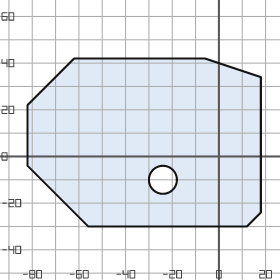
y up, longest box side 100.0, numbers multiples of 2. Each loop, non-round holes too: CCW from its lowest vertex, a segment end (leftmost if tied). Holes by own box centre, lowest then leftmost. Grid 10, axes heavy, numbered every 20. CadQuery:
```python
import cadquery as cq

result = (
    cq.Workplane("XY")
    .moveTo(-56.0, -30.0)
    .lineTo(12.0, -30.0)
    .lineTo(18.0, -24.0)
    .lineTo(18.0, 34.0)
    .lineTo(-6.0, 42.0)
    .lineTo(-62.0, 42.0)
    .lineTo(-82.0, 22.0)
    .lineTo(-82.0, -4.0)
    .close()
    .moveTo(-24.0, -10.0)
    .circle(6.0)
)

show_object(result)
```